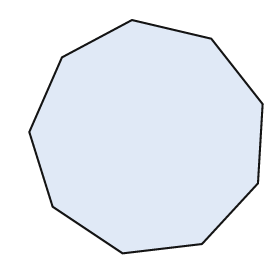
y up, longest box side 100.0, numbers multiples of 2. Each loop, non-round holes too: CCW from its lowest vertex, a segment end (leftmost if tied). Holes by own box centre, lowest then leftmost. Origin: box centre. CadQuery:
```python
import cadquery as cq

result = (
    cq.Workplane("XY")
    .moveTo(-10.0, -50.0)
    .lineTo(24.0, -46.0)
    .lineTo(48.0, -20.0)
    .lineTo(50.0, 14.0)
    .lineTo(28.0, 42.0)
    .lineTo(-6.0, 50.0)
    .lineTo(-36.0, 34.0)
    .lineTo(-50.0, 2.0)
    .lineTo(-40.0, -30.0)
    .close()
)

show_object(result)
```